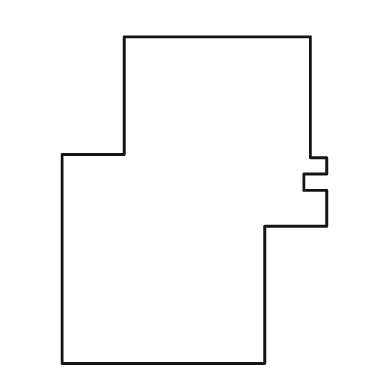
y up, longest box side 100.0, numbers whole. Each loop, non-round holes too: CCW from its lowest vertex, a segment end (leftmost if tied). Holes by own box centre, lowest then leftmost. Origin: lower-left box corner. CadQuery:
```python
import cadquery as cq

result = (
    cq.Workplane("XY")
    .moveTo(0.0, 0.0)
    .lineTo(62.0, 0.0)
    .lineTo(62.0, 42.0)
    .lineTo(81.0, 42.0)
    .lineTo(81.0, 53.0)
    .lineTo(74.0, 53.0)
    .lineTo(74.0, 58.0)
    .lineTo(81.0, 58.0)
    .lineTo(81.0, 63.0)
    .lineTo(76.0, 63.0)
    .lineTo(76.0, 100.0)
    .lineTo(19.0, 100.0)
    .lineTo(19.0, 64.0)
    .lineTo(0.0, 64.0)
    .close()
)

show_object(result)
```